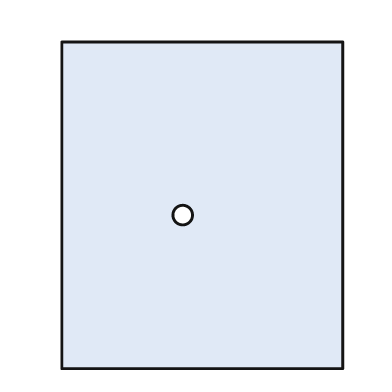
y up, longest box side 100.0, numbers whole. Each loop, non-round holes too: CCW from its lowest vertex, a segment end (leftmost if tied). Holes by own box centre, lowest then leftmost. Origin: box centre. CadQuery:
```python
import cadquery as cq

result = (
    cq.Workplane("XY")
    .moveTo(-43.0, -50.0)
    .lineTo(43.0, -50.0)
    .lineTo(43.0, 50.0)
    .lineTo(-43.0, 50.0)
    .close()
    .moveTo(-6.0, -3.0)
    .circle(3.0)
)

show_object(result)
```